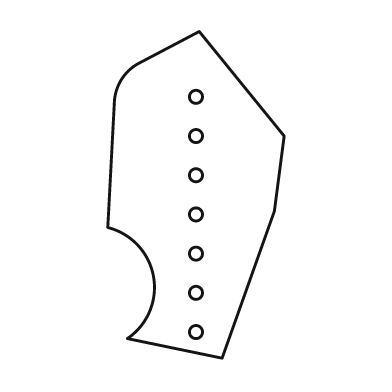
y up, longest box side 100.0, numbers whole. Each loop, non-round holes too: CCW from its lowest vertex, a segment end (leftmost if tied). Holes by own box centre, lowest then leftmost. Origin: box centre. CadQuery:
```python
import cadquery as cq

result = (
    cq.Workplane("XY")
    .moveTo(8.0, -50.0)
    .lineTo(24.0, -5.0)
    .lineTo(27.0, 18.0)
    .lineTo(1.0, 50.0)
    .lineTo(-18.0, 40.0)
    .threePointArc((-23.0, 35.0), (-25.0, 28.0))
    .lineTo(-27.0, -10.0)
    .threePointArc((-13.0, -25.0), (-21.0, -44.0))
    .close()
    .moveTo(0.0, -42.0)
    .circle(2.0)
    .moveTo(0.0, -30.0)
    .circle(2.0)
    .moveTo(0.0, -18.0)
    .circle(2.0)
    .moveTo(0.0, -6.0)
    .circle(2.0)
    .moveTo(0.0, 6.0)
    .circle(2.0)
    .moveTo(0.0, 18.0)
    .circle(2.0)
    .moveTo(0.0, 30.0)
    .circle(2.0)
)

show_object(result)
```